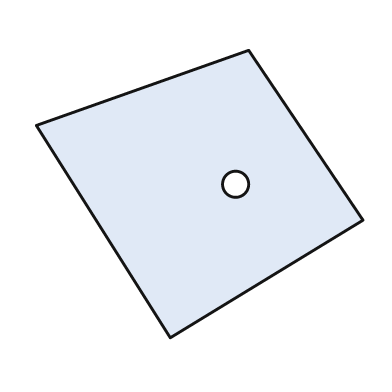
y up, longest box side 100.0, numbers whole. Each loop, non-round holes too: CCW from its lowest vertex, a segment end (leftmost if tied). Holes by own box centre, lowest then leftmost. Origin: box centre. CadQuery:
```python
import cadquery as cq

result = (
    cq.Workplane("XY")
    .moveTo(-9.0, -44.0)
    .lineTo(50.0, -8.0)
    .lineTo(15.0, 44.0)
    .lineTo(-50.0, 21.0)
    .close()
    .moveTo(11.0, 3.0)
    .circle(4.0)
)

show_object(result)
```